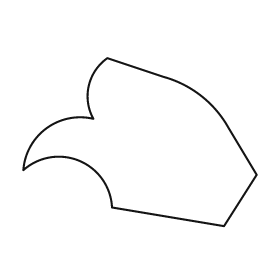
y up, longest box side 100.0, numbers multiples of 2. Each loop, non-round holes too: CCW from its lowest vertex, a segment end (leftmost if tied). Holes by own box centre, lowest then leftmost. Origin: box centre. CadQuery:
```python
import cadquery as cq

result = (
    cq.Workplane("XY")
    .moveTo(36.0, -36.0)
    .lineTo(50.0, -14.0)
    .lineTo(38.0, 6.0)
    .threePointArc((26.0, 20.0), (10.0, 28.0))
    .lineTo(-14.0, 36.0)
    .threePointArc((-22.0, 24.0), (-20.0, 10.0))
    .threePointArc((-40.0, 6.0), (-50.0, -12.0))
    .threePointArc((-26.0, -8.0), (-12.0, -28.0))
    .close()
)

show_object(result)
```